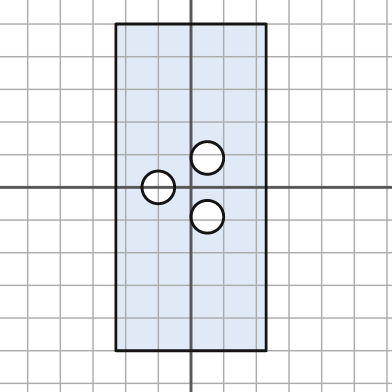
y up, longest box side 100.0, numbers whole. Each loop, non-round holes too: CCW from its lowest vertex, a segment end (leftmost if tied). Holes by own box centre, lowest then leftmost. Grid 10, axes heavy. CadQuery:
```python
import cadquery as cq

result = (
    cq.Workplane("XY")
    .moveTo(-23.0, -50.0)
    .lineTo(23.0, -50.0)
    .lineTo(23.0, 50.0)
    .lineTo(-23.0, 50.0)
    .close()
    .moveTo(5.0, -9.0)
    .circle(5.0)
    .moveTo(-10.0, 0.0)
    .circle(5.0)
    .moveTo(5.0, 9.0)
    .circle(5.0)
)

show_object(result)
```